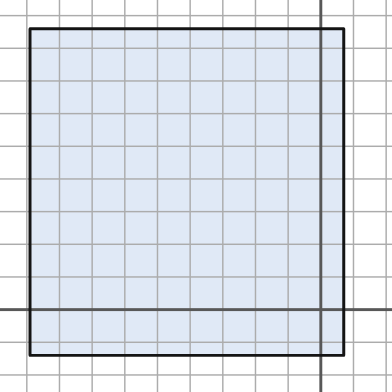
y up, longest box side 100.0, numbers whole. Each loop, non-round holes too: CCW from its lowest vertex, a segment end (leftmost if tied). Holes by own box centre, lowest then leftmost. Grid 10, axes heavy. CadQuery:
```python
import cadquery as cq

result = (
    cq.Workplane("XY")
    .moveTo(-89.0, -14.0)
    .lineTo(7.0, -14.0)
    .lineTo(7.0, 86.0)
    .lineTo(-89.0, 86.0)
    .close()
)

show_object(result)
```